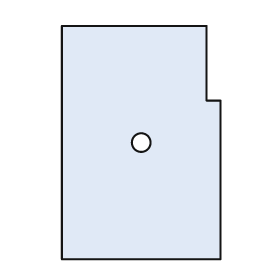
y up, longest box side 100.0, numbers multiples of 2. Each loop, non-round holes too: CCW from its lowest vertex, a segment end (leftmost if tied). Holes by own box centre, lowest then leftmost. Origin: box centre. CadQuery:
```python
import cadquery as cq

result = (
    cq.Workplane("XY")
    .moveTo(-34.0, -50.0)
    .lineTo(34.0, -50.0)
    .lineTo(34.0, 18.0)
    .lineTo(28.0, 18.0)
    .lineTo(28.0, 50.0)
    .lineTo(-34.0, 50.0)
    .close()
    .moveTo(0.0, 0.0)
    .circle(4.0)
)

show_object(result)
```